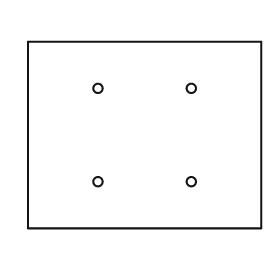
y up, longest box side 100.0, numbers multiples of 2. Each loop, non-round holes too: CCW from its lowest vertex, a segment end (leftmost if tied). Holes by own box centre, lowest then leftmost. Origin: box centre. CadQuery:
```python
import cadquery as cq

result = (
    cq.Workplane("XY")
    .moveTo(-50.0, -40.0)
    .lineTo(50.0, -40.0)
    .lineTo(50.0, 40.0)
    .lineTo(-50.0, 40.0)
    .close()
    .moveTo(-20.0, -20.0)
    .circle(2.0)
    .moveTo(20.0, -20.0)
    .circle(2.0)
    .moveTo(-20.0, 20.0)
    .circle(2.0)
    .moveTo(20.0, 20.0)
    .circle(2.0)
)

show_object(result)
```